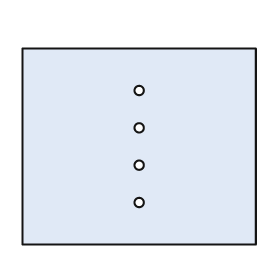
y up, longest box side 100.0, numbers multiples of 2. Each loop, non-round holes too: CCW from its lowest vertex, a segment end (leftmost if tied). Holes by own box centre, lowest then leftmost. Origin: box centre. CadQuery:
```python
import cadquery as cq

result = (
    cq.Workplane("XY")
    .moveTo(-50.0, -42.0)
    .lineTo(50.0, -42.0)
    .lineTo(50.0, 42.0)
    .lineTo(-50.0, 42.0)
    .close()
    .moveTo(0.0, -24.0)
    .circle(2.0)
    .moveTo(0.0, -8.0)
    .circle(2.0)
    .moveTo(0.0, 8.0)
    .circle(2.0)
    .moveTo(0.0, 24.0)
    .circle(2.0)
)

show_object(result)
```